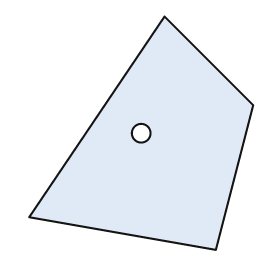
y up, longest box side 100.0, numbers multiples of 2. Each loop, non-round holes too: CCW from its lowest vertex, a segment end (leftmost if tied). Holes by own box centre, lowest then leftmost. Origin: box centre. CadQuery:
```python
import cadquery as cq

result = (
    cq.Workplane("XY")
    .moveTo(32.0, -50.0)
    .lineTo(48.0, 12.0)
    .lineTo(10.0, 50.0)
    .lineTo(-48.0, -36.0)
    .close()
    .moveTo(0.0, 0.0)
    .circle(4.0)
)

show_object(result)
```